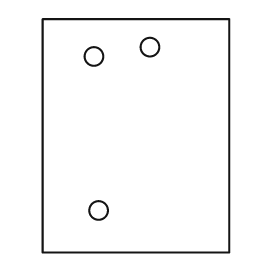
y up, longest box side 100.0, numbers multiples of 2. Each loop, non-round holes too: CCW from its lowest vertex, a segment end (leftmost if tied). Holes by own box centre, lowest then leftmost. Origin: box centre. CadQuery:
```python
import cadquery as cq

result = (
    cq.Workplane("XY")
    .moveTo(-40.0, -50.0)
    .lineTo(40.0, -50.0)
    .lineTo(40.0, 50.0)
    .lineTo(-40.0, 50.0)
    .close()
    .moveTo(-16.0, -32.0)
    .circle(4.0)
    .moveTo(-18.0, 34.0)
    .circle(4.0)
    .moveTo(6.0, 38.0)
    .circle(4.0)
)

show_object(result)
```